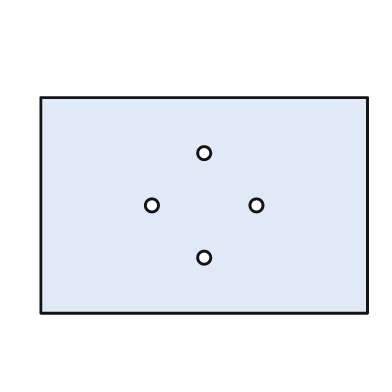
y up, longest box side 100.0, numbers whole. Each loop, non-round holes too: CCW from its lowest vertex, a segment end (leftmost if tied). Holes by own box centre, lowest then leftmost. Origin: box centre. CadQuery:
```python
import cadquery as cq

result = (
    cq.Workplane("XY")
    .moveTo(-50.0, -33.0)
    .lineTo(50.0, -33.0)
    .lineTo(50.0, 33.0)
    .lineTo(-50.0, 33.0)
    .close()
    .moveTo(0.0, -16.0)
    .circle(2.0)
    .moveTo(-16.0, 0.0)
    .circle(2.0)
    .moveTo(16.0, 0.0)
    .circle(2.0)
    .moveTo(0.0, 16.0)
    .circle(2.0)
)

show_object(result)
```